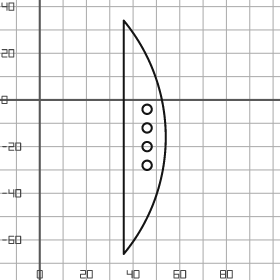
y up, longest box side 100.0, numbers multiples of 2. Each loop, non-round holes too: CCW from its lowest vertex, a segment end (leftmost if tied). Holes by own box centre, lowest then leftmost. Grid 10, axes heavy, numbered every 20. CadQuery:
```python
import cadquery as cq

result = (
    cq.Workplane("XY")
    .moveTo(36.0, -66.0)
    .threePointArc((54.0, -16.0), (36.0, 34.0))
    .close()
    .moveTo(46.0, -28.0)
    .circle(2.0)
    .moveTo(46.0, -20.0)
    .circle(2.0)
    .moveTo(46.0, -12.0)
    .circle(2.0)
    .moveTo(46.0, -4.0)
    .circle(2.0)
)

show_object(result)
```